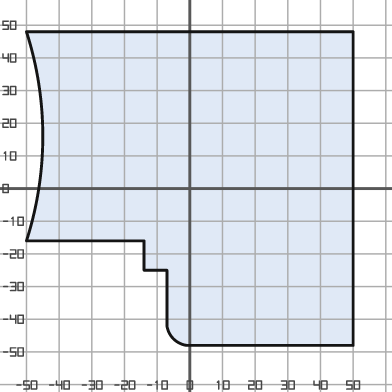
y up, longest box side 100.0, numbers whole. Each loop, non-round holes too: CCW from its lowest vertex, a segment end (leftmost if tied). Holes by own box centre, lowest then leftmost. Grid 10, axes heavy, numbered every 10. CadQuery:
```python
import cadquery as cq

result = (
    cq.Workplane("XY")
    .moveTo(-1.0, -48.0)
    .lineTo(50.0, -48.0)
    .lineTo(50.0, 48.0)
    .lineTo(-50.0, 48.0)
    .threePointArc((-45.0, 16.0), (-50.0, -16.0))
    .lineTo(-14.0, -16.0)
    .lineTo(-14.0, -25.0)
    .lineTo(-7.0, -25.0)
    .lineTo(-7.0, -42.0)
    .threePointArc((-5.0, -46.0), (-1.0, -48.0))
    .close()
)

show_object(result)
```